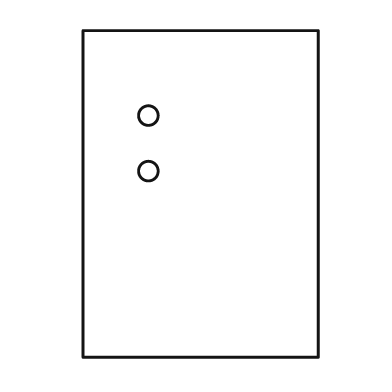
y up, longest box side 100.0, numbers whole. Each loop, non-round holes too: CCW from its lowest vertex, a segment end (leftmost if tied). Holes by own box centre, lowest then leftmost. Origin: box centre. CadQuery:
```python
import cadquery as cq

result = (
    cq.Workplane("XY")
    .moveTo(-36.0, -50.0)
    .lineTo(36.0, -50.0)
    .lineTo(36.0, 50.0)
    .lineTo(-36.0, 50.0)
    .close()
    .moveTo(-16.0, 7.0)
    .circle(3.0)
    .moveTo(-16.0, 24.0)
    .circle(3.0)
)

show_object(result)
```